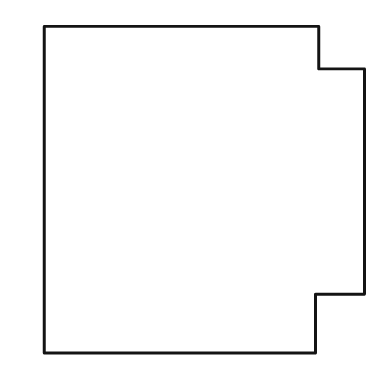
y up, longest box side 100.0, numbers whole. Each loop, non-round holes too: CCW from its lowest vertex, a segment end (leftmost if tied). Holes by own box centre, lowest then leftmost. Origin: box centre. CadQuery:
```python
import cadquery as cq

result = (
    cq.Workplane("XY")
    .moveTo(-49.0, -50.0)
    .lineTo(34.0, -50.0)
    .lineTo(34.0, -32.0)
    .lineTo(49.0, -32.0)
    .lineTo(49.0, 37.0)
    .lineTo(35.0, 37.0)
    .lineTo(35.0, 50.0)
    .lineTo(-49.0, 50.0)
    .close()
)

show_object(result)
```